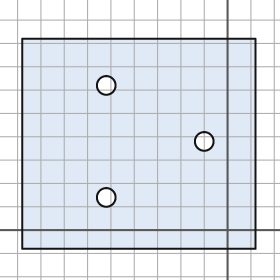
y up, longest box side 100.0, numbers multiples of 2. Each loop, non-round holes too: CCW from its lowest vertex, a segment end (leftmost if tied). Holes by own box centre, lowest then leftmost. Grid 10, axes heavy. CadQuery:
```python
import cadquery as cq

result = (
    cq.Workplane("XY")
    .moveTo(-88.0, -8.0)
    .lineTo(12.0, -8.0)
    .lineTo(12.0, 82.0)
    .lineTo(-88.0, 82.0)
    .close()
    .moveTo(-52.0, 14.0)
    .circle(4.0)
    .moveTo(-10.0, 38.0)
    .circle(4.0)
    .moveTo(-52.0, 62.0)
    .circle(4.0)
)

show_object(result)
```